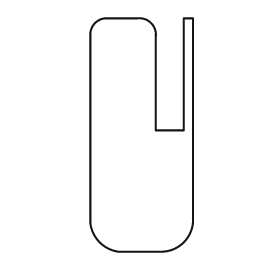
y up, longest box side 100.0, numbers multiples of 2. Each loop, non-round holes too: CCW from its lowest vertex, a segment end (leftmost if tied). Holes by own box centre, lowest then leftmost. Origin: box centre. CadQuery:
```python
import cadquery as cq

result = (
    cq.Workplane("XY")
    .moveTo(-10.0, -50.0)
    .lineTo(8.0, -50.0)
    .threePointArc((18.0, -46.0), (22.0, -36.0))
    .lineTo(22.0, 50.0)
    .lineTo(18.0, 50.0)
    .lineTo(18.0, 2.0)
    .lineTo(6.0, 2.0)
    .lineTo(6.0, 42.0)
    .threePointArc((4.0, 48.0), (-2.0, 50.0))
    .lineTo(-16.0, 50.0)
    .threePointArc((-20.0, 48.0), (-22.0, 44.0))
    .lineTo(-22.0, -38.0)
    .threePointArc((-18.0, -46.0), (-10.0, -50.0))
    .close()
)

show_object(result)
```